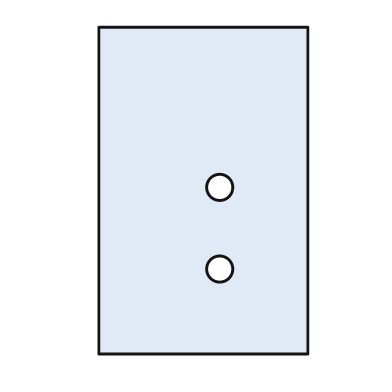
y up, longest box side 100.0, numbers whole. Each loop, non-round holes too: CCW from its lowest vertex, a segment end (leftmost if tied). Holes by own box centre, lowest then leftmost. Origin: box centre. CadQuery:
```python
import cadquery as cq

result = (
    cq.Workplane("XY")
    .moveTo(-32.0, -50.0)
    .lineTo(32.0, -50.0)
    .lineTo(32.0, 50.0)
    .lineTo(-32.0, 50.0)
    .close()
    .moveTo(5.0, -24.0)
    .circle(4.0)
    .moveTo(5.0, 1.0)
    .circle(4.0)
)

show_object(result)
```